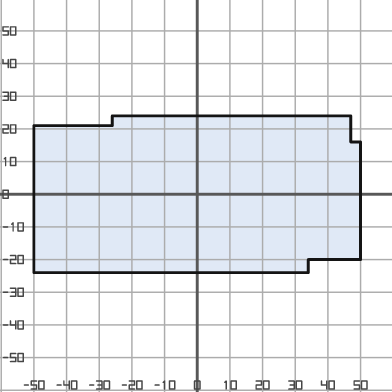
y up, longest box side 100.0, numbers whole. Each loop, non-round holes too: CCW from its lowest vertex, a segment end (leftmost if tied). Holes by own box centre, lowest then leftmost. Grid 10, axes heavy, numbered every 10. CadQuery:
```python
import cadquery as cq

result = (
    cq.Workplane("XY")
    .moveTo(-50.0, -24.0)
    .lineTo(34.0, -24.0)
    .lineTo(34.0, -20.0)
    .lineTo(50.0, -20.0)
    .lineTo(50.0, 16.0)
    .lineTo(47.0, 16.0)
    .lineTo(47.0, 24.0)
    .lineTo(-26.0, 24.0)
    .lineTo(-26.0, 21.0)
    .lineTo(-50.0, 21.0)
    .close()
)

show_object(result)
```